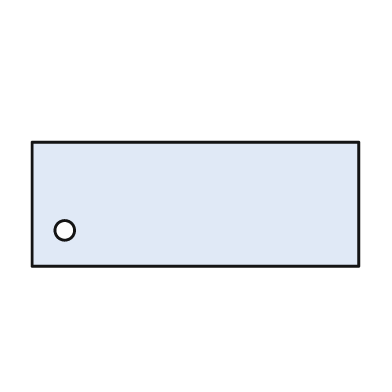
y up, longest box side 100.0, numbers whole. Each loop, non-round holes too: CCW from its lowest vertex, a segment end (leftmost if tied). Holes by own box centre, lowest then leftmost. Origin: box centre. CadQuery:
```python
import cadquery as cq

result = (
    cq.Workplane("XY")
    .moveTo(-50.0, -19.0)
    .lineTo(50.0, -19.0)
    .lineTo(50.0, 19.0)
    .lineTo(-50.0, 19.0)
    .close()
    .moveTo(-40.0, -8.0)
    .circle(3.0)
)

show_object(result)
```